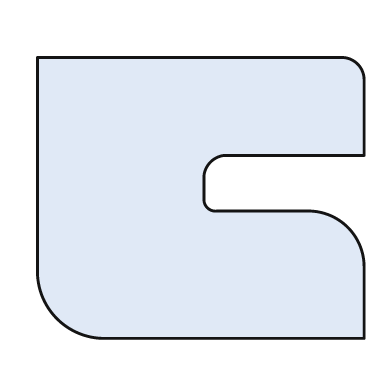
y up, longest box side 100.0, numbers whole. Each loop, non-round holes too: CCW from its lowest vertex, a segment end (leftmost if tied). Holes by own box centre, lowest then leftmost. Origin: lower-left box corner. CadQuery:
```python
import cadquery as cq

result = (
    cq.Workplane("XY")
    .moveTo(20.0, 0.0)
    .lineTo(100.0, 0.0)
    .lineTo(100.0, 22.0)
    .threePointArc((95.0, 34.0), (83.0, 39.0))
    .lineTo(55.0, 39.0)
    .threePointArc((52.0, 40.0), (51.0, 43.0))
    .lineTo(51.0, 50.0)
    .threePointArc((53.0, 54.0), (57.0, 56.0))
    .lineTo(100.0, 56.0)
    .lineTo(100.0, 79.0)
    .threePointArc((98.0, 84.0), (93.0, 86.0))
    .lineTo(0.0, 86.0)
    .lineTo(0.0, 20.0)
    .threePointArc((6.0, 6.0), (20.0, 0.0))
    .close()
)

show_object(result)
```